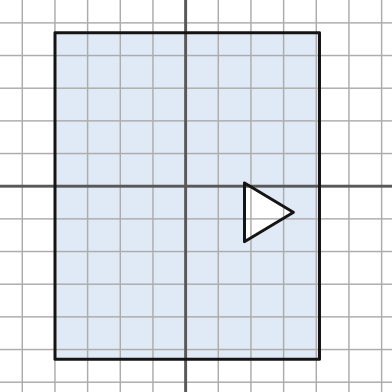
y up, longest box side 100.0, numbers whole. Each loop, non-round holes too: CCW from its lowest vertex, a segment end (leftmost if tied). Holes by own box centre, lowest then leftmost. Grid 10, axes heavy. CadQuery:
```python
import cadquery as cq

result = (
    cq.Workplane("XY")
    .moveTo(-40.0, -53.0)
    .lineTo(41.0, -53.0)
    .lineTo(41.0, 47.0)
    .lineTo(-40.0, 47.0)
    .close()
    .moveTo(18.0, -17.0)
    .lineTo(33.0, -8.0)
    .lineTo(18.0, 1.0)
    .close()
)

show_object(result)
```